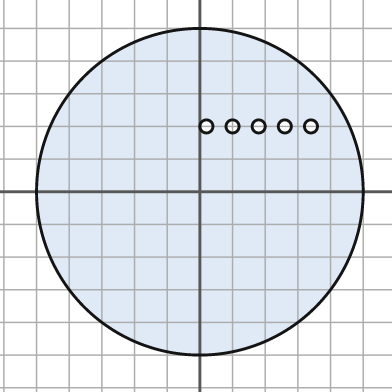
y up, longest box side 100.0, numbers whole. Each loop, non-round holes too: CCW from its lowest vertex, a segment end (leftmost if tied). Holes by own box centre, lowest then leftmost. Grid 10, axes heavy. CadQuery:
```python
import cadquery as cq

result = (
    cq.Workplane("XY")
    .moveTo(0.0, 0.0)
    .circle(50.0)
    .moveTo(2.0, 20.0)
    .circle(2.0)
    .moveTo(10.0, 20.0)
    .circle(2.0)
    .moveTo(18.0, 20.0)
    .circle(2.0)
    .moveTo(26.0, 20.0)
    .circle(2.0)
    .moveTo(34.0, 20.0)
    .circle(2.0)
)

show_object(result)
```